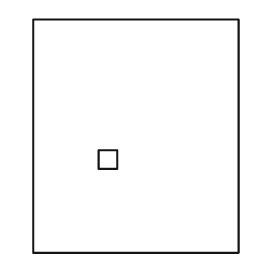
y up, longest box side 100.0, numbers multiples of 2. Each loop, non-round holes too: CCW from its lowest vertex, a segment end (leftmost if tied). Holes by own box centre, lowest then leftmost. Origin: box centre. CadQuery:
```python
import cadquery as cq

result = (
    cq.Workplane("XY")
    .moveTo(-44.0, -50.0)
    .lineTo(44.0, -50.0)
    .lineTo(44.0, 50.0)
    .lineTo(-44.0, 50.0)
    .close()
    .moveTo(-16.0, -14.0)
    .lineTo(-8.0, -14.0)
    .lineTo(-8.0, -6.0)
    .lineTo(-16.0, -6.0)
    .close()
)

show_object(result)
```